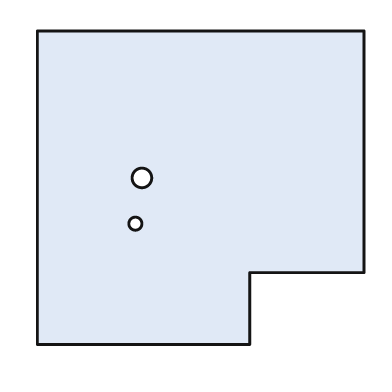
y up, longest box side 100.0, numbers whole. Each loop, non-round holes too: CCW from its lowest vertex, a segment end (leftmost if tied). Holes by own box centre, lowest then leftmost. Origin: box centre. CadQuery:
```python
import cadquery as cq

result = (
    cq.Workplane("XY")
    .moveTo(-50.0, -48.0)
    .lineTo(15.0, -48.0)
    .lineTo(15.0, -26.0)
    .lineTo(50.0, -26.0)
    .lineTo(50.0, 48.0)
    .lineTo(-50.0, 48.0)
    .close()
    .moveTo(-20.0, -11.0)
    .circle(2.0)
    .moveTo(-18.0, 3.0)
    .circle(3.0)
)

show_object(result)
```